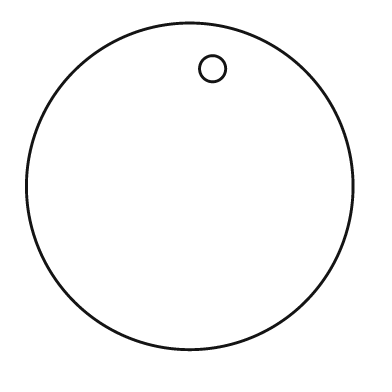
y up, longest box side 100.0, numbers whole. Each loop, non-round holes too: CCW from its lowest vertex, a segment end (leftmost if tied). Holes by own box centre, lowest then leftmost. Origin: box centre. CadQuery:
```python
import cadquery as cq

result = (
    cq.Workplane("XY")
    .moveTo(0.0, 0.0)
    .circle(50.0)
    .moveTo(7.0, 36.0)
    .circle(4.0)
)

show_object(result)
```